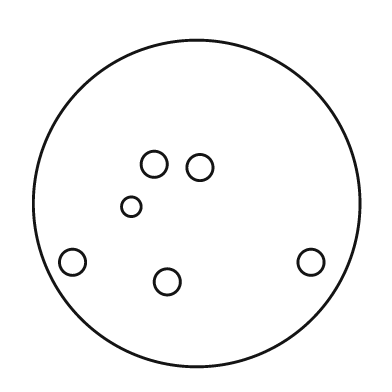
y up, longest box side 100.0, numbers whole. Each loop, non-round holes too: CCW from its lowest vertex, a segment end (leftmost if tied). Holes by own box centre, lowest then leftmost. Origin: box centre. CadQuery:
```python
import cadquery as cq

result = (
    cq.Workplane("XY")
    .moveTo(0.0, 0.0)
    .circle(50.0)
    .moveTo(-9.0, -24.0)
    .circle(4.0)
    .moveTo(-38.0, -18.0)
    .circle(4.0)
    .moveTo(35.0, -18.0)
    .circle(4.0)
    .moveTo(-20.0, -1.0)
    .circle(3.0)
    .moveTo(1.0, 11.0)
    .circle(4.0)
    .moveTo(-13.0, 12.0)
    .circle(4.0)
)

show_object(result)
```